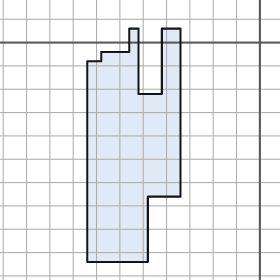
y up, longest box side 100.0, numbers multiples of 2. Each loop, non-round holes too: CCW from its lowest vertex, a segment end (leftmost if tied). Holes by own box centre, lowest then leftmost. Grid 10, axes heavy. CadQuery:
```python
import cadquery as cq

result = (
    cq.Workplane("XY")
    .moveTo(-74.0, -94.0)
    .lineTo(-48.0, -94.0)
    .lineTo(-48.0, -66.0)
    .lineTo(-34.0, -66.0)
    .lineTo(-34.0, 6.0)
    .lineTo(-42.0, 6.0)
    .lineTo(-42.0, -22.0)
    .lineTo(-52.0, -22.0)
    .lineTo(-52.0, 6.0)
    .lineTo(-56.0, 6.0)
    .lineTo(-56.0, -4.0)
    .lineTo(-68.0, -4.0)
    .lineTo(-68.0, -8.0)
    .lineTo(-74.0, -8.0)
    .close()
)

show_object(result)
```